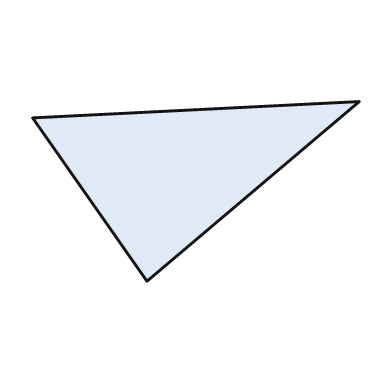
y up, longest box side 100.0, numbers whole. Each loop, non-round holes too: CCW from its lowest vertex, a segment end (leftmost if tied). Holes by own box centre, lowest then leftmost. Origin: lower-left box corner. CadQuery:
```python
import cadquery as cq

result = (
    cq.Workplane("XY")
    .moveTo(35.0, 0.0)
    .lineTo(100.0, 55.0)
    .lineTo(0.0, 50.0)
    .close()
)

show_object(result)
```